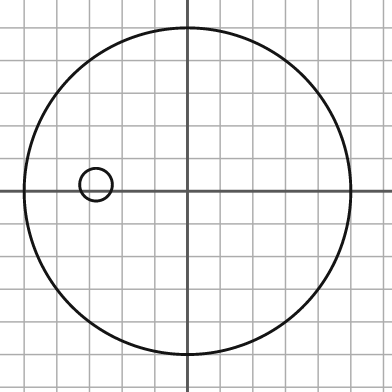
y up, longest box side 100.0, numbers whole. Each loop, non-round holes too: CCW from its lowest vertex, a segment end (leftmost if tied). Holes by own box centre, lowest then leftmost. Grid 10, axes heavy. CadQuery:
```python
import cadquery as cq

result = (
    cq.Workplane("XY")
    .moveTo(0.0, 0.0)
    .circle(50.0)
    .moveTo(-28.0, 2.0)
    .circle(5.0)
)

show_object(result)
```